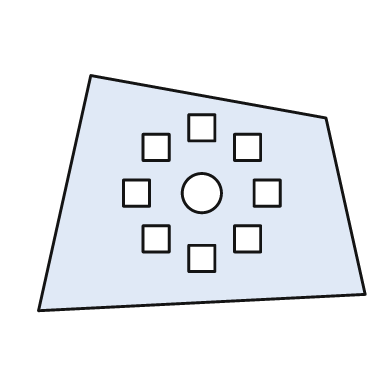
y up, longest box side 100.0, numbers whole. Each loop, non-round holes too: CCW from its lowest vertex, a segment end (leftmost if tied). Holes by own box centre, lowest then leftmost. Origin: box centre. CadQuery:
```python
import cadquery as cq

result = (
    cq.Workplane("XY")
    .moveTo(-50.0, -36.0)
    .lineTo(50.0, -31.0)
    .lineTo(38.0, 23.0)
    .lineTo(-34.0, 36.0)
    .close()
    .moveTo(-4.0, -24.0)
    .lineTo(4.0, -24.0)
    .lineTo(4.0, -16.0)
    .lineTo(-4.0, -16.0)
    .close()
    .moveTo(-18.0, -18.0)
    .lineTo(-10.0, -18.0)
    .lineTo(-10.0, -10.0)
    .lineTo(-18.0, -10.0)
    .close()
    .moveTo(10.0, -18.0)
    .lineTo(18.0, -18.0)
    .lineTo(18.0, -10.0)
    .lineTo(10.0, -10.0)
    .close()
    .moveTo(-24.0, -4.0)
    .lineTo(-16.0, -4.0)
    .lineTo(-16.0, 4.0)
    .lineTo(-24.0, 4.0)
    .close()
    .moveTo(0.0, 0.0)
    .circle(6.0)
    .moveTo(16.0, -4.0)
    .lineTo(24.0, -4.0)
    .lineTo(24.0, 4.0)
    .lineTo(16.0, 4.0)
    .close()
    .moveTo(-18.0, 10.0)
    .lineTo(-10.0, 10.0)
    .lineTo(-10.0, 18.0)
    .lineTo(-18.0, 18.0)
    .close()
    .moveTo(10.0, 10.0)
    .lineTo(18.0, 10.0)
    .lineTo(18.0, 18.0)
    .lineTo(10.0, 18.0)
    .close()
    .moveTo(-4.0, 16.0)
    .lineTo(4.0, 16.0)
    .lineTo(4.0, 24.0)
    .lineTo(-4.0, 24.0)
    .close()
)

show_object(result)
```